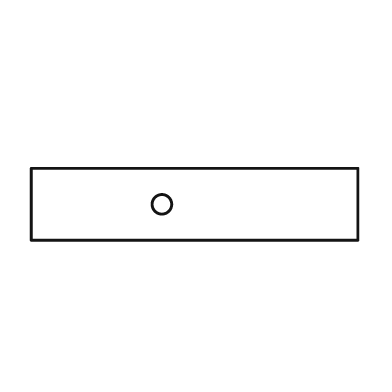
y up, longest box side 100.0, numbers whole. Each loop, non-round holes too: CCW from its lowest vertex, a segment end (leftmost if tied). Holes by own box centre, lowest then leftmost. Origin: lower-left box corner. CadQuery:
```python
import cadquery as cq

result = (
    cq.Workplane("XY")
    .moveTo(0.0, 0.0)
    .lineTo(100.0, 0.0)
    .lineTo(100.0, 22.0)
    .lineTo(0.0, 22.0)
    .close()
    .moveTo(40.0, 11.0)
    .circle(3.0)
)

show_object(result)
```